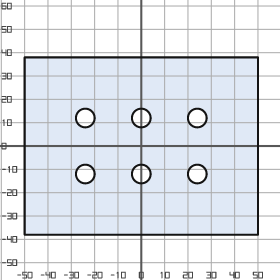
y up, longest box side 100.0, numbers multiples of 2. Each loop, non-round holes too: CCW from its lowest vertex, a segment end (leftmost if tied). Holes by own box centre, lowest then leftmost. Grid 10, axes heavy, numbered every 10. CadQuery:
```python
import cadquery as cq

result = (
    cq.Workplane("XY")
    .moveTo(-50.0, -38.0)
    .lineTo(50.0, -38.0)
    .lineTo(50.0, 38.0)
    .lineTo(-50.0, 38.0)
    .close()
    .moveTo(-24.0, -12.0)
    .circle(4.0)
    .moveTo(0.0, -12.0)
    .circle(4.0)
    .moveTo(24.0, -12.0)
    .circle(4.0)
    .moveTo(-24.0, 12.0)
    .circle(4.0)
    .moveTo(0.0, 12.0)
    .circle(4.0)
    .moveTo(24.0, 12.0)
    .circle(4.0)
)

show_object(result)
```